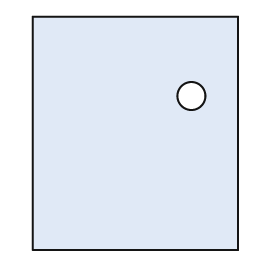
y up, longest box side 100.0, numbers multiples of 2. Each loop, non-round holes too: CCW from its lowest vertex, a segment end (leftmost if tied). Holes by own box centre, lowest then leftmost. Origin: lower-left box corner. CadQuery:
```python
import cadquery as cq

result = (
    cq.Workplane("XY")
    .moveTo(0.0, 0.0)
    .lineTo(88.0, 0.0)
    .lineTo(88.0, 100.0)
    .lineTo(0.0, 100.0)
    .close()
    .moveTo(68.0, 66.0)
    .circle(6.0)
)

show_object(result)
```